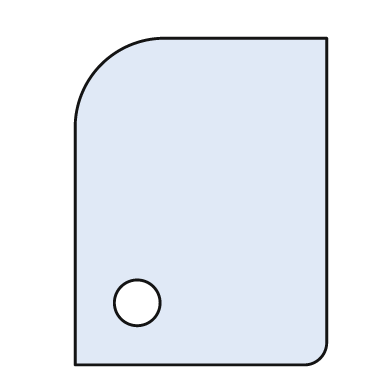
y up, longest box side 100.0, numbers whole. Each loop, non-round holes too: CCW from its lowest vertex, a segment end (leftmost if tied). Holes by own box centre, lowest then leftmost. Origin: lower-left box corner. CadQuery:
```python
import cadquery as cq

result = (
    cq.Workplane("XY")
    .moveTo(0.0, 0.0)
    .lineTo(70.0, 0.0)
    .threePointArc((75.0, 2.0), (77.0, 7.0))
    .lineTo(77.0, 100.0)
    .lineTo(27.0, 100.0)
    .threePointArc((8.0, 92.0), (0.0, 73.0))
    .close()
    .moveTo(19.0, 19.0)
    .circle(7.0)
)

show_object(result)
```